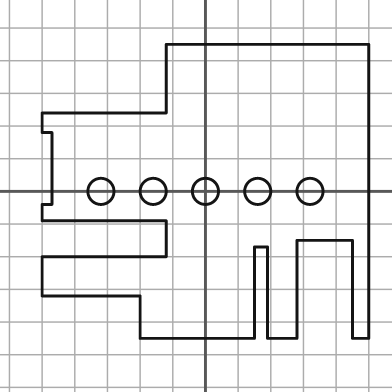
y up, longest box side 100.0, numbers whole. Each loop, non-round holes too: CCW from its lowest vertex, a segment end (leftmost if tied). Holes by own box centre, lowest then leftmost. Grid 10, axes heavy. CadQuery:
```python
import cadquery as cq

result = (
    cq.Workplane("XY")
    .moveTo(-20.0, -45.0)
    .lineTo(15.0, -45.0)
    .lineTo(15.0, -17.0)
    .lineTo(19.0, -17.0)
    .lineTo(19.0, -45.0)
    .lineTo(28.0, -45.0)
    .lineTo(28.0, -15.0)
    .lineTo(45.0, -15.0)
    .lineTo(45.0, -45.0)
    .lineTo(50.0, -45.0)
    .lineTo(50.0, 45.0)
    .lineTo(-12.0, 45.0)
    .lineTo(-12.0, 24.0)
    .lineTo(-50.0, 24.0)
    .lineTo(-50.0, 18.0)
    .lineTo(-47.0, 18.0)
    .lineTo(-47.0, -4.0)
    .lineTo(-50.0, -4.0)
    .lineTo(-50.0, -9.0)
    .lineTo(-12.0, -9.0)
    .lineTo(-12.0, -20.0)
    .lineTo(-50.0, -20.0)
    .lineTo(-50.0, -32.0)
    .lineTo(-20.0, -32.0)
    .close()
    .moveTo(-32.0, 0.0)
    .circle(4.0)
    .moveTo(-16.0, 0.0)
    .circle(4.0)
    .moveTo(0.0, 0.0)
    .circle(4.0)
    .moveTo(16.0, 0.0)
    .circle(4.0)
    .moveTo(32.0, 0.0)
    .circle(4.0)
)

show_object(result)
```